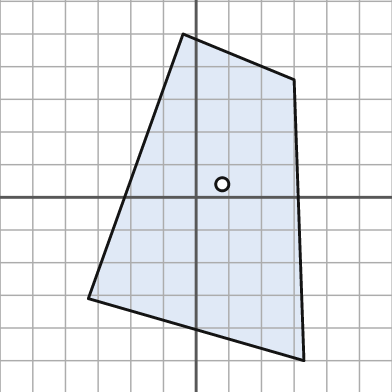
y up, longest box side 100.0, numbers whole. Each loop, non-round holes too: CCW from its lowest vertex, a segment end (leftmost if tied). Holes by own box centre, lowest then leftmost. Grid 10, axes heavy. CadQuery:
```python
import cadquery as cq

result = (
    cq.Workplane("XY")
    .moveTo(33.0, -50.0)
    .lineTo(30.0, 36.0)
    .lineTo(-4.0, 50.0)
    .lineTo(-33.0, -31.0)
    .close()
    .moveTo(8.0, 4.0)
    .circle(2.0)
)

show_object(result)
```